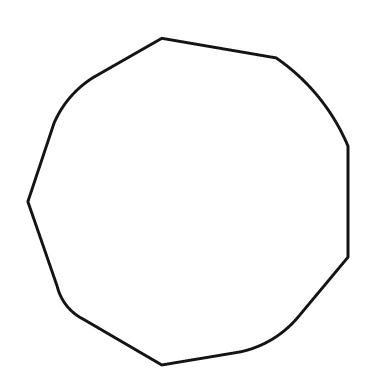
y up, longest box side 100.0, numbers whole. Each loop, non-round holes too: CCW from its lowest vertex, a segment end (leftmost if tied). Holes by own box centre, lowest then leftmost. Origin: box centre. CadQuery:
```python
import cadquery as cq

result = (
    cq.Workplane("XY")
    .moveTo(-8.0, -50.0)
    .lineTo(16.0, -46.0)
    .threePointArc((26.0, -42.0), (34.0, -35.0))
    .lineTo(49.0, -17.0)
    .lineTo(49.0, 17.0)
    .threePointArc((40.0, 32.0), (27.0, 44.0))
    .lineTo(-8.0, 50.0)
    .lineTo(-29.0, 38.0)
    .threePointArc((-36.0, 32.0), (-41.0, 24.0))
    .lineTo(-49.0, 0.0)
    .lineTo(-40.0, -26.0)
    .threePointArc((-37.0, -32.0), (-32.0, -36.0))
    .close()
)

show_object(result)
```